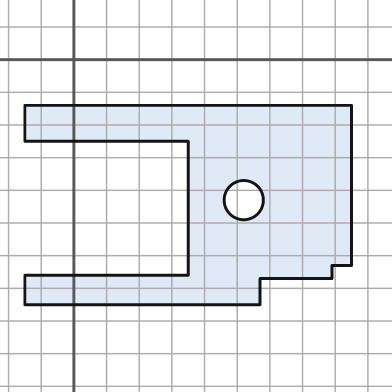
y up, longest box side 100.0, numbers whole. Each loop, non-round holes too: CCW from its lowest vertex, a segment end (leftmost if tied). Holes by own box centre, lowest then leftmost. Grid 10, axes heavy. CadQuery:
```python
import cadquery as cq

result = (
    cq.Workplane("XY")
    .moveTo(-15.0, -75.0)
    .lineTo(57.0, -75.0)
    .lineTo(57.0, -67.0)
    .lineTo(79.0, -67.0)
    .lineTo(79.0, -63.0)
    .lineTo(85.0, -63.0)
    .lineTo(85.0, -14.0)
    .lineTo(-15.0, -14.0)
    .lineTo(-15.0, -25.0)
    .lineTo(35.0, -25.0)
    .lineTo(35.0, -66.0)
    .lineTo(-15.0, -66.0)
    .close()
    .moveTo(52.0, -43.0)
    .circle(6.0)
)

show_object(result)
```